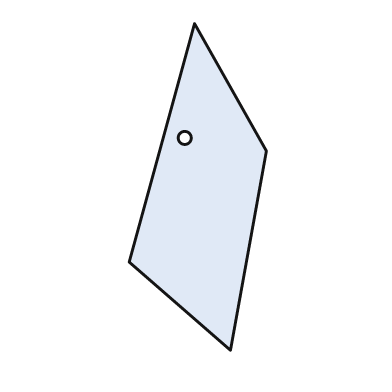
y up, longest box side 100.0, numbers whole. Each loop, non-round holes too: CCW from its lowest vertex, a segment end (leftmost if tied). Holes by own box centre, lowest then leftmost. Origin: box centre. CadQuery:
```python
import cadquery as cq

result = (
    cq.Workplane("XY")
    .moveTo(10.0, -50.0)
    .lineTo(21.0, 11.0)
    .lineTo(-1.0, 50.0)
    .lineTo(-21.0, -23.0)
    .close()
    .moveTo(-4.0, 15.0)
    .circle(2.0)
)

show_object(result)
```